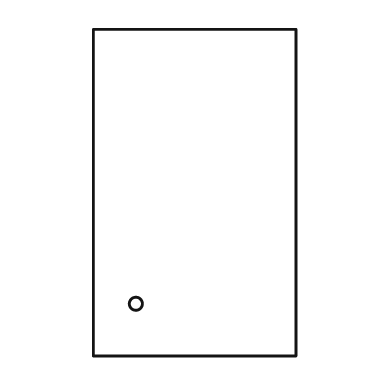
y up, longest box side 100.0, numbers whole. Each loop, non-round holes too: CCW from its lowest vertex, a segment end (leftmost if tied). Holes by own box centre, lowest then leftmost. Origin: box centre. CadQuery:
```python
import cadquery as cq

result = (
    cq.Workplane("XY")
    .moveTo(-31.0, -50.0)
    .lineTo(31.0, -50.0)
    .lineTo(31.0, 50.0)
    .lineTo(-31.0, 50.0)
    .close()
    .moveTo(-18.0, -34.0)
    .circle(2.0)
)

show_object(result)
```